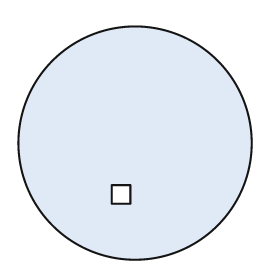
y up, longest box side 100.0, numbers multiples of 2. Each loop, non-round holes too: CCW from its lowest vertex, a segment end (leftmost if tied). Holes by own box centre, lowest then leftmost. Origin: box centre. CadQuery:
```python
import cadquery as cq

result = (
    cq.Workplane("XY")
    .moveTo(0.0, 0.0)
    .circle(50.0)
    .moveTo(-10.0, -26.0)
    .lineTo(-2.0, -26.0)
    .lineTo(-2.0, -18.0)
    .lineTo(-10.0, -18.0)
    .close()
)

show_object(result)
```